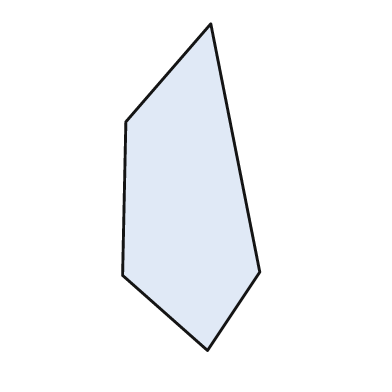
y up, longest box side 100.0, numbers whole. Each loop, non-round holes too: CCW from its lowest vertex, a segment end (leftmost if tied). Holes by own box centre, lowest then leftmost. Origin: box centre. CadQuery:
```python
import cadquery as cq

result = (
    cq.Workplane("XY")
    .moveTo(5.0, -50.0)
    .lineTo(21.0, -26.0)
    .lineTo(6.0, 50.0)
    .lineTo(-20.0, 20.0)
    .lineTo(-21.0, -27.0)
    .close()
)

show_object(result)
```